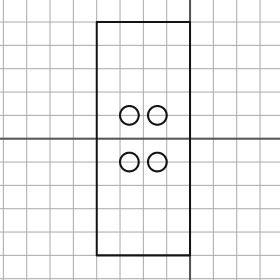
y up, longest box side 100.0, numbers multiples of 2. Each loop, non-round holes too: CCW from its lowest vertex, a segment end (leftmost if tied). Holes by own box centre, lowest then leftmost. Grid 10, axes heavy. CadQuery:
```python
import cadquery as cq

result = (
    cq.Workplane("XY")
    .moveTo(-40.0, -50.0)
    .lineTo(0.0, -50.0)
    .lineTo(0.0, 50.0)
    .lineTo(-40.0, 50.0)
    .close()
    .moveTo(-26.0, -10.0)
    .circle(4.0)
    .moveTo(-14.0, -10.0)
    .circle(4.0)
    .moveTo(-26.0, 10.0)
    .circle(4.0)
    .moveTo(-14.0, 10.0)
    .circle(4.0)
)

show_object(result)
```